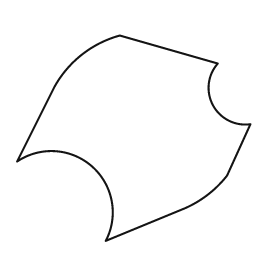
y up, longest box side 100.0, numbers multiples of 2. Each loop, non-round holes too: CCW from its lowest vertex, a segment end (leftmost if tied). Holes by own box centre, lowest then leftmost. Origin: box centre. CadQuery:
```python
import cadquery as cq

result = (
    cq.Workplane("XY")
    .moveTo(-12.0, -44.0)
    .lineTo(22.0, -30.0)
    .threePointArc((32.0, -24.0), (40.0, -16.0))
    .lineTo(50.0, 6.0)
    .threePointArc((34.0, 14.0), (36.0, 32.0))
    .lineTo(-6.0, 44.0)
    .threePointArc((-22.0, 36.0), (-34.0, 22.0))
    .lineTo(-50.0, -10.0)
    .threePointArc((-18.0, -12.0), (-12.0, -44.0))
    .close()
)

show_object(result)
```